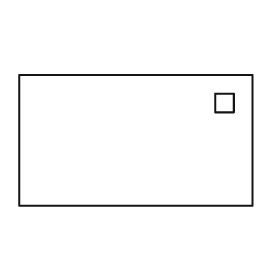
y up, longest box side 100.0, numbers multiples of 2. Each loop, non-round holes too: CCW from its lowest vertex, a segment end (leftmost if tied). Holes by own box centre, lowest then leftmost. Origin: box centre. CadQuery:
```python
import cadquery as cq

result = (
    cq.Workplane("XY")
    .moveTo(-50.0, -28.0)
    .lineTo(50.0, -28.0)
    .lineTo(50.0, 28.0)
    .lineTo(-50.0, 28.0)
    .close()
    .moveTo(34.0, 12.0)
    .lineTo(42.0, 12.0)
    .lineTo(42.0, 20.0)
    .lineTo(34.0, 20.0)
    .close()
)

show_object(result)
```